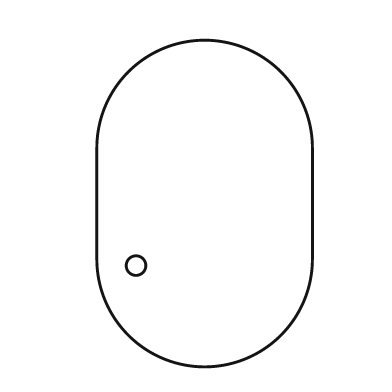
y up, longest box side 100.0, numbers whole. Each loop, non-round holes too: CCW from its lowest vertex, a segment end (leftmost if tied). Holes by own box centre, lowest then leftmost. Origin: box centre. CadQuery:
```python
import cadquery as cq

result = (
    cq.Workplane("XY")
    .moveTo(-33.0, -17.0)
    .threePointArc((0.0, -50.0), (33.0, -17.0))
    .lineTo(33.0, 17.0)
    .threePointArc((0.0, 50.0), (-33.0, 17.0))
    .close()
    .moveTo(-21.0, -19.0)
    .circle(3.0)
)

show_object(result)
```